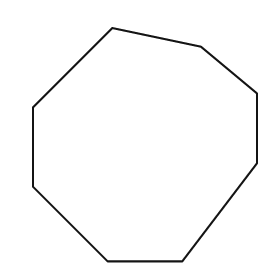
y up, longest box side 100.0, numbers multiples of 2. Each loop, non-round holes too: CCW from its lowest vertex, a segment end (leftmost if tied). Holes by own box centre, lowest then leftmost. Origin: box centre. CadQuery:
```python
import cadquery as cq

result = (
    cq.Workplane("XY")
    .moveTo(-16.0, -50.0)
    .lineTo(16.0, -50.0)
    .lineTo(48.0, -8.0)
    .lineTo(48.0, 22.0)
    .lineTo(24.0, 42.0)
    .lineTo(-14.0, 50.0)
    .lineTo(-48.0, 16.0)
    .lineTo(-48.0, -18.0)
    .close()
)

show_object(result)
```